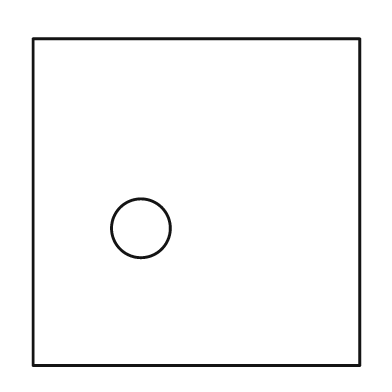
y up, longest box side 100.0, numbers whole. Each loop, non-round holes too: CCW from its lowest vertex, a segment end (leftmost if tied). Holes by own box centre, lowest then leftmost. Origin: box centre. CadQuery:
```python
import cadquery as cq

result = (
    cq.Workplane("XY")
    .moveTo(-50.0, -50.0)
    .lineTo(50.0, -50.0)
    .lineTo(50.0, 50.0)
    .lineTo(-50.0, 50.0)
    .close()
    .moveTo(-17.0, -8.0)
    .circle(9.0)
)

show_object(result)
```